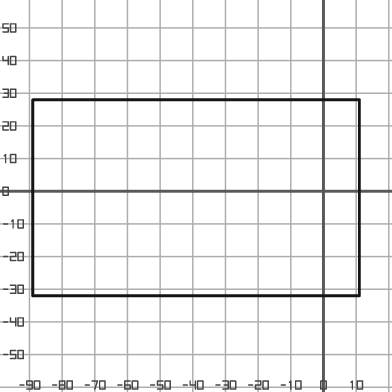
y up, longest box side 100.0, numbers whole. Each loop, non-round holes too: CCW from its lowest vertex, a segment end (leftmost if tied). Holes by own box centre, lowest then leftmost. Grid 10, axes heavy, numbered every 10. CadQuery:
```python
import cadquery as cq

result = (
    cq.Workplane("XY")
    .moveTo(-89.0, -32.0)
    .lineTo(11.0, -32.0)
    .lineTo(11.0, 28.0)
    .lineTo(-89.0, 28.0)
    .close()
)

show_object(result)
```